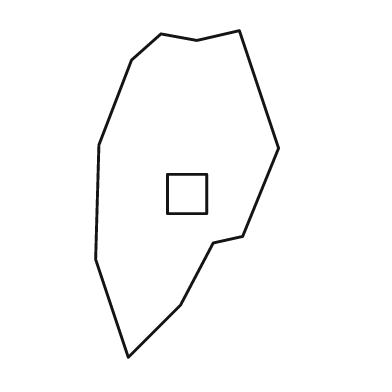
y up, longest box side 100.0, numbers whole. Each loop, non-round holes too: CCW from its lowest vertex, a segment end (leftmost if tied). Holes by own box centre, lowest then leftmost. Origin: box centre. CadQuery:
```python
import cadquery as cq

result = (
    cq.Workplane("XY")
    .moveTo(-18.0, -50.0)
    .lineTo(-2.0, -34.0)
    .lineTo(8.0, -15.0)
    .lineTo(17.0, -13.0)
    .lineTo(28.0, 14.0)
    .lineTo(16.0, 50.0)
    .lineTo(3.0, 47.0)
    .lineTo(-8.0, 49.0)
    .lineTo(-17.0, 41.0)
    .lineTo(-27.0, 15.0)
    .lineTo(-28.0, -20.0)
    .close()
    .moveTo(-6.0, -6.0)
    .lineTo(6.0, -6.0)
    .lineTo(6.0, 6.0)
    .lineTo(-6.0, 6.0)
    .close()
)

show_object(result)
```